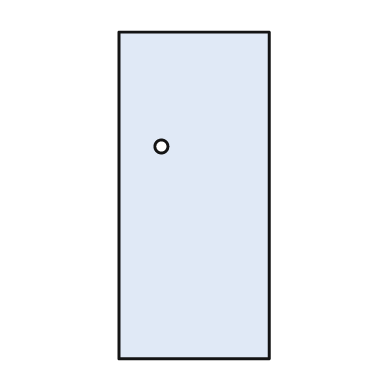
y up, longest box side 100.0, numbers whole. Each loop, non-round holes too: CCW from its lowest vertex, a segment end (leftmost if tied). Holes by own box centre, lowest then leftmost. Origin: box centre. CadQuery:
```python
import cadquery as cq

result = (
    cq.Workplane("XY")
    .moveTo(-23.0, -50.0)
    .lineTo(23.0, -50.0)
    .lineTo(23.0, 50.0)
    .lineTo(-23.0, 50.0)
    .close()
    .moveTo(-10.0, 15.0)
    .circle(2.0)
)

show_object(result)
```